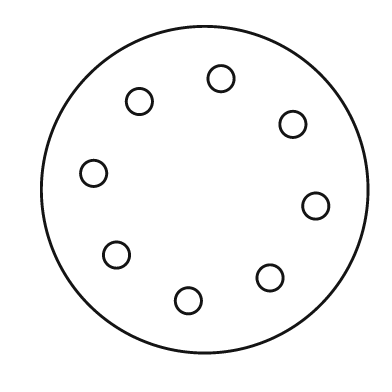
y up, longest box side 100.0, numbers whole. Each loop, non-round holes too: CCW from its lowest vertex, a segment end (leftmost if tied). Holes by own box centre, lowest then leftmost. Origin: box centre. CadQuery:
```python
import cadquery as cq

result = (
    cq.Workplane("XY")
    .moveTo(0.0, 0.0)
    .circle(50.0)
    .moveTo(-5.0, -34.0)
    .circle(4.0)
    .moveTo(20.0, -27.0)
    .circle(4.0)
    .moveTo(-27.0, -20.0)
    .circle(4.0)
    .moveTo(34.0, -5.0)
    .circle(4.0)
    .moveTo(-34.0, 5.0)
    .circle(4.0)
    .moveTo(27.0, 20.0)
    .circle(4.0)
    .moveTo(-20.0, 27.0)
    .circle(4.0)
    .moveTo(5.0, 34.0)
    .circle(4.0)
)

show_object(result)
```